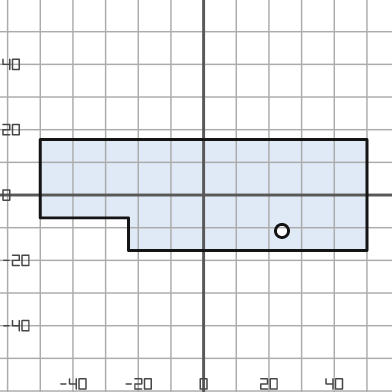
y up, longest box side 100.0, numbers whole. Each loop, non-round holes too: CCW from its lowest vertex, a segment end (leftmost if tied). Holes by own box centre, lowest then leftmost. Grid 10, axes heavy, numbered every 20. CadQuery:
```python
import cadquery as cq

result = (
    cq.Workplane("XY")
    .moveTo(-23.0, -17.0)
    .lineTo(50.0, -17.0)
    .lineTo(50.0, 17.0)
    .lineTo(-50.0, 17.0)
    .lineTo(-50.0, -7.0)
    .lineTo(-23.0, -7.0)
    .close()
    .moveTo(24.0, -11.0)
    .circle(2.0)
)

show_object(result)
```